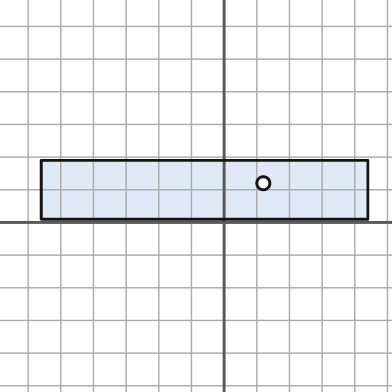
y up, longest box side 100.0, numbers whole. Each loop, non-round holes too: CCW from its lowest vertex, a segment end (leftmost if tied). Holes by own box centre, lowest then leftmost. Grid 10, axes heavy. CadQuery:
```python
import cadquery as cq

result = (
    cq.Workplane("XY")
    .moveTo(-56.0, 1.0)
    .lineTo(44.0, 1.0)
    .lineTo(44.0, 19.0)
    .lineTo(-56.0, 19.0)
    .close()
    .moveTo(12.0, 12.0)
    .circle(2.0)
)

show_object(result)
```